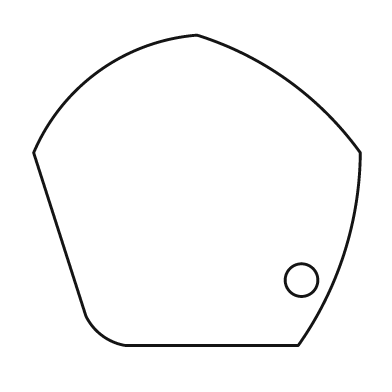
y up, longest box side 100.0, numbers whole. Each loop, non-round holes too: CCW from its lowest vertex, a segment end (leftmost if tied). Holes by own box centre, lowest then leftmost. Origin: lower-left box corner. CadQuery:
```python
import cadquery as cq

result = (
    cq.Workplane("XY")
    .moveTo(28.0, 0.0)
    .lineTo(81.0, 0.0)
    .threePointArc((95.0, 28.0), (100.0, 59.0))
    .threePointArc((78.0, 81.0), (50.0, 95.0))
    .threePointArc((20.0, 84.0), (0.0, 59.0))
    .lineTo(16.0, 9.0)
    .threePointArc((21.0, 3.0), (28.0, 0.0))
    .close()
    .moveTo(82.0, 20.0)
    .circle(5.0)
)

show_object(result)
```